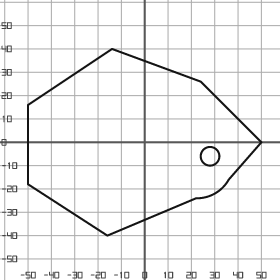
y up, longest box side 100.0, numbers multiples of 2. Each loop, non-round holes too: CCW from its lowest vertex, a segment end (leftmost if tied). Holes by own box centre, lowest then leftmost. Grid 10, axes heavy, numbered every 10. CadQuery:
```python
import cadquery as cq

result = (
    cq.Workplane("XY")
    .moveTo(-16.0, -40.0)
    .lineTo(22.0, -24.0)
    .threePointArc((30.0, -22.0), (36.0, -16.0))
    .lineTo(50.0, 0.0)
    .lineTo(24.0, 26.0)
    .lineTo(-14.0, 40.0)
    .lineTo(-50.0, 16.0)
    .lineTo(-50.0, -18.0)
    .close()
    .moveTo(28.0, -6.0)
    .circle(4.0)
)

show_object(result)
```